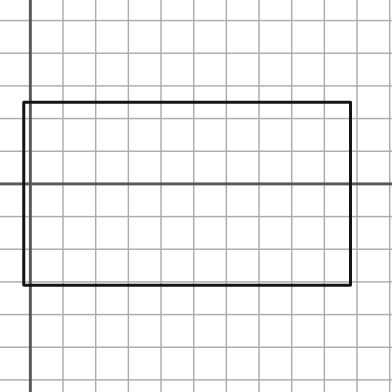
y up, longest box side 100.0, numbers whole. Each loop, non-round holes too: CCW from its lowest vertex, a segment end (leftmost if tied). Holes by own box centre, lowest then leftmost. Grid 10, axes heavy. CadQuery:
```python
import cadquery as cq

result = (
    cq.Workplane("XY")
    .moveTo(-2.0, -31.0)
    .lineTo(98.0, -31.0)
    .lineTo(98.0, 25.0)
    .lineTo(-2.0, 25.0)
    .close()
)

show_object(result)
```